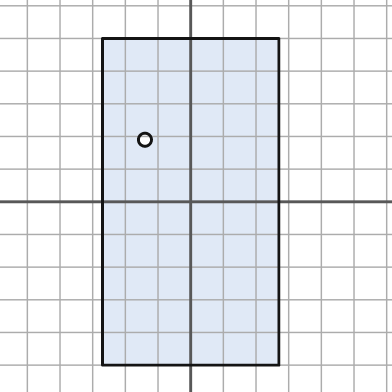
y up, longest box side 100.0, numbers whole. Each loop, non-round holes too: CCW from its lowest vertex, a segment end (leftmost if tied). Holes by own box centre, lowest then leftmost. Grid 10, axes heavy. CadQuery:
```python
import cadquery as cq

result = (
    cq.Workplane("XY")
    .moveTo(-27.0, -50.0)
    .lineTo(27.0, -50.0)
    .lineTo(27.0, 50.0)
    .lineTo(-27.0, 50.0)
    .close()
    .moveTo(-14.0, 19.0)
    .circle(2.0)
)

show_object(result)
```